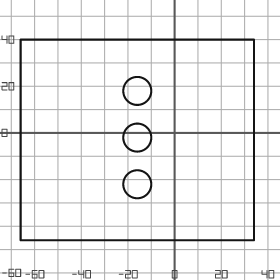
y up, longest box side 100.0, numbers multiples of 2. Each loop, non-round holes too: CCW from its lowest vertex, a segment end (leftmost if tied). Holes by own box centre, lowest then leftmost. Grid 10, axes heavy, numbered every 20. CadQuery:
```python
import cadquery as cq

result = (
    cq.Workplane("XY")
    .moveTo(-66.0, -46.0)
    .lineTo(34.0, -46.0)
    .lineTo(34.0, 40.0)
    .lineTo(-66.0, 40.0)
    .close()
    .moveTo(-16.0, -22.0)
    .circle(6.0)
    .moveTo(-16.0, -2.0)
    .circle(6.0)
    .moveTo(-16.0, 18.0)
    .circle(6.0)
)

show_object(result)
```